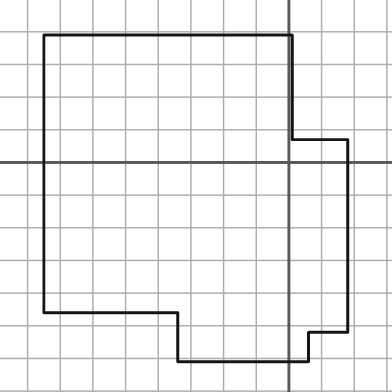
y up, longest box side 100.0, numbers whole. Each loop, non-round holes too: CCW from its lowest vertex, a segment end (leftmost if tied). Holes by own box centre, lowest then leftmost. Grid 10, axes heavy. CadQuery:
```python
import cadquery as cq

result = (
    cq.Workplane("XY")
    .moveTo(-34.0, -61.0)
    .lineTo(6.0, -61.0)
    .lineTo(6.0, -52.0)
    .lineTo(18.0, -52.0)
    .lineTo(18.0, 7.0)
    .lineTo(1.0, 7.0)
    .lineTo(1.0, 39.0)
    .lineTo(-75.0, 39.0)
    .lineTo(-75.0, -46.0)
    .lineTo(-34.0, -46.0)
    .close()
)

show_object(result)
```